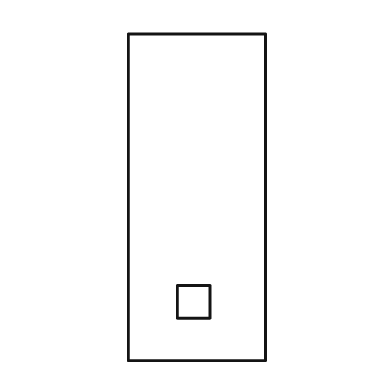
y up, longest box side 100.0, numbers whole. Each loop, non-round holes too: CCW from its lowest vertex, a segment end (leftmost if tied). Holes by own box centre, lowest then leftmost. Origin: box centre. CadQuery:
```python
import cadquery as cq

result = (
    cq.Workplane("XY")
    .moveTo(-21.0, -50.0)
    .lineTo(21.0, -50.0)
    .lineTo(21.0, 50.0)
    .lineTo(-21.0, 50.0)
    .close()
    .moveTo(-6.0, -37.0)
    .lineTo(4.0, -37.0)
    .lineTo(4.0, -27.0)
    .lineTo(-6.0, -27.0)
    .close()
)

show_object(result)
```